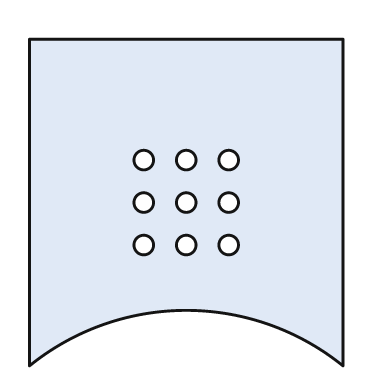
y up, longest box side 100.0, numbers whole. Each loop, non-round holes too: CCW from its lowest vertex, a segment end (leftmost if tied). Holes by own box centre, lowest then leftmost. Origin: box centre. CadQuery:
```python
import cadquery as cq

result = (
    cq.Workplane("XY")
    .moveTo(-48.0, -50.0)
    .threePointArc((0.0, -33.0), (48.0, -50.0))
    .lineTo(48.0, 50.0)
    .lineTo(-48.0, 50.0)
    .close()
    .moveTo(-13.0, -13.0)
    .circle(3.0)
    .moveTo(0.0, -13.0)
    .circle(3.0)
    .moveTo(13.0, -13.0)
    .circle(3.0)
    .moveTo(-13.0, 0.0)
    .circle(3.0)
    .moveTo(0.0, 0.0)
    .circle(3.0)
    .moveTo(13.0, 0.0)
    .circle(3.0)
    .moveTo(-13.0, 13.0)
    .circle(3.0)
    .moveTo(0.0, 13.0)
    .circle(3.0)
    .moveTo(13.0, 13.0)
    .circle(3.0)
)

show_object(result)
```